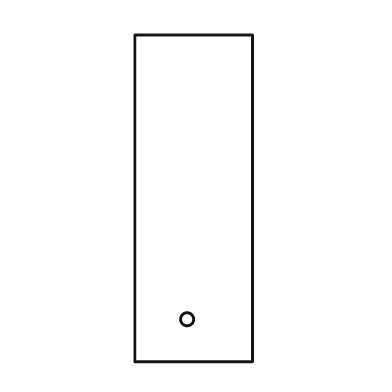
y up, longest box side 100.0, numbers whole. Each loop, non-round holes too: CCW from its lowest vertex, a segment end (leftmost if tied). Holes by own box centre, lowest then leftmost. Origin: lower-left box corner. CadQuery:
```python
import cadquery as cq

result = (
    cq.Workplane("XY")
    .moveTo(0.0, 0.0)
    .lineTo(36.0, 0.0)
    .lineTo(36.0, 100.0)
    .lineTo(0.0, 100.0)
    .close()
    .moveTo(16.0, 13.0)
    .circle(2.0)
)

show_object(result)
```